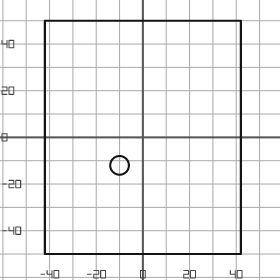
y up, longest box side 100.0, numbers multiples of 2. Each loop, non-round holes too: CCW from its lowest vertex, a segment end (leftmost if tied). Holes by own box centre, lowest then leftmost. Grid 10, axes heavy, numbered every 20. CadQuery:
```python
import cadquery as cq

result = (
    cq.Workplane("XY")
    .moveTo(-42.0, -50.0)
    .lineTo(42.0, -50.0)
    .lineTo(42.0, 50.0)
    .lineTo(-42.0, 50.0)
    .close()
    .moveTo(-10.0, -12.0)
    .circle(4.0)
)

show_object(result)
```